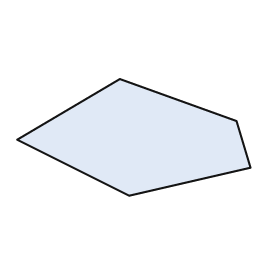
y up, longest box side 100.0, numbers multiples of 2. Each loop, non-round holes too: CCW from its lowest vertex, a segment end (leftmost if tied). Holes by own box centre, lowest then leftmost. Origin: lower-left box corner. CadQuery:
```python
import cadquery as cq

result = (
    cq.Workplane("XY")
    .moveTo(48.0, 0.0)
    .lineTo(100.0, 12.0)
    .lineTo(94.0, 32.0)
    .lineTo(44.0, 50.0)
    .lineTo(0.0, 24.0)
    .close()
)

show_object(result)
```